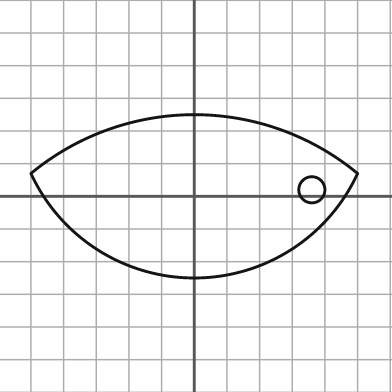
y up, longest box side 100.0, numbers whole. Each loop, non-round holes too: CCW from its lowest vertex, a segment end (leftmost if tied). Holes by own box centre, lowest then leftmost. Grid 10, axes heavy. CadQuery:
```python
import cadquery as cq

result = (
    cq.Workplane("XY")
    .moveTo(-50.0, 7.0)
    .threePointArc((0.0, -25.0), (50.0, 7.0))
    .threePointArc((0.0, 25.0), (-50.0, 7.0))
    .close()
    .moveTo(36.0, 2.0)
    .circle(4.0)
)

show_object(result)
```